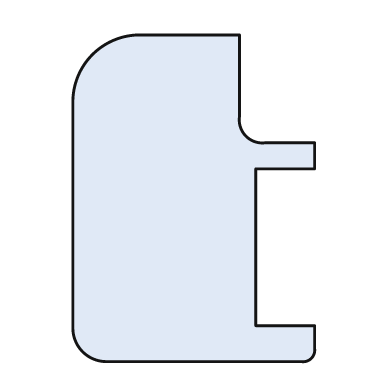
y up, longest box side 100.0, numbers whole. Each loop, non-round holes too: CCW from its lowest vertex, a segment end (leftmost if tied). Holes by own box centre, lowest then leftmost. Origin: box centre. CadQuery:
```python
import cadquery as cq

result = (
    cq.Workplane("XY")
    .moveTo(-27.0, -50.0)
    .lineTo(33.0, -50.0)
    .threePointArc((36.0, -49.0), (37.0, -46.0))
    .lineTo(37.0, -39.0)
    .lineTo(19.0, -39.0)
    .lineTo(19.0, 9.0)
    .lineTo(37.0, 9.0)
    .lineTo(37.0, 17.0)
    .lineTo(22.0, 17.0)
    .threePointArc((16.0, 19.0), (14.0, 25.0))
    .lineTo(14.0, 50.0)
    .lineTo(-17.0, 50.0)
    .threePointArc((-31.0, 44.0), (-37.0, 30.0))
    .lineTo(-37.0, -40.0)
    .threePointArc((-34.0, -47.0), (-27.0, -50.0))
    .close()
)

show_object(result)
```